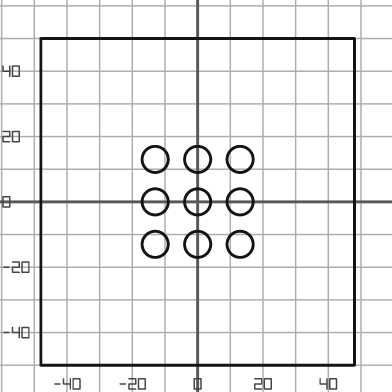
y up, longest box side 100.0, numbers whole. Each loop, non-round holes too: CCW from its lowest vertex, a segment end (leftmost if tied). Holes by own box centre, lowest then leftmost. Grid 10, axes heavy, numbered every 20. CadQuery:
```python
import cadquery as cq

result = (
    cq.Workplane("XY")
    .moveTo(-48.0, -50.0)
    .lineTo(48.0, -50.0)
    .lineTo(48.0, 50.0)
    .lineTo(-48.0, 50.0)
    .close()
    .moveTo(-13.0, -13.0)
    .circle(4.0)
    .moveTo(0.0, -13.0)
    .circle(4.0)
    .moveTo(13.0, -13.0)
    .circle(4.0)
    .moveTo(-13.0, 0.0)
    .circle(4.0)
    .moveTo(0.0, 0.0)
    .circle(4.0)
    .moveTo(13.0, 0.0)
    .circle(4.0)
    .moveTo(-13.0, 13.0)
    .circle(4.0)
    .moveTo(0.0, 13.0)
    .circle(4.0)
    .moveTo(13.0, 13.0)
    .circle(4.0)
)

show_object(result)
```